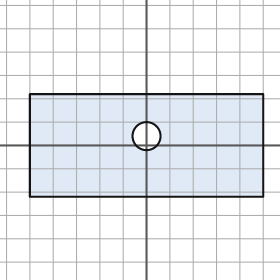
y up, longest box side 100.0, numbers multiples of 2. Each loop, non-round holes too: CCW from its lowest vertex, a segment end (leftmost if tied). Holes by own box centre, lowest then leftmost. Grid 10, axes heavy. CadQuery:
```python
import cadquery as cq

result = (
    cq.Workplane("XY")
    .moveTo(-50.0, -22.0)
    .lineTo(50.0, -22.0)
    .lineTo(50.0, 22.0)
    .lineTo(-50.0, 22.0)
    .close()
    .moveTo(0.0, 4.0)
    .circle(6.0)
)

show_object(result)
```